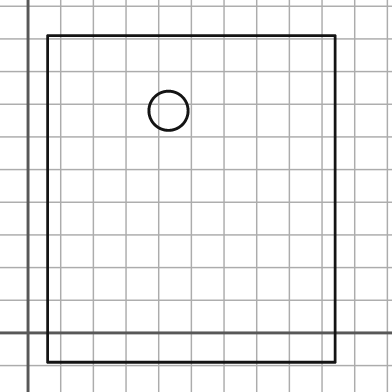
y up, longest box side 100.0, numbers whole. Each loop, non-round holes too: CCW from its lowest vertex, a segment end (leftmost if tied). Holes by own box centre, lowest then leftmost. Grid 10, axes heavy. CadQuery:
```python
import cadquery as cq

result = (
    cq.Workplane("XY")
    .moveTo(6.0, -9.0)
    .lineTo(94.0, -9.0)
    .lineTo(94.0, 91.0)
    .lineTo(6.0, 91.0)
    .close()
    .moveTo(43.0, 68.0)
    .circle(6.0)
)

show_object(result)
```